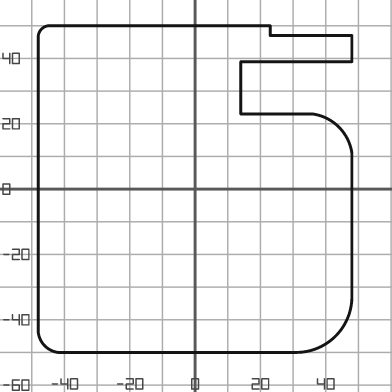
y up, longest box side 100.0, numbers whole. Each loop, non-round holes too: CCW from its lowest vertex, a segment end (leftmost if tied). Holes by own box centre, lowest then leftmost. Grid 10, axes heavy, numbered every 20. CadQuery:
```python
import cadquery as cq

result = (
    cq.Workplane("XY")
    .moveTo(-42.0, -50.0)
    .lineTo(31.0, -50.0)
    .threePointArc((43.0, -45.0), (48.0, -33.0))
    .lineTo(48.0, 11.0)
    .threePointArc((44.0, 19.0), (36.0, 23.0))
    .lineTo(14.0, 23.0)
    .lineTo(14.0, 39.0)
    .lineTo(48.0, 39.0)
    .lineTo(48.0, 47.0)
    .lineTo(23.0, 47.0)
    .lineTo(23.0, 50.0)
    .lineTo(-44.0, 50.0)
    .threePointArc((-47.0, 49.0), (-48.0, 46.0))
    .lineTo(-48.0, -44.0)
    .threePointArc((-46.0, -48.0), (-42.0, -50.0))
    .close()
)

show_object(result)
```